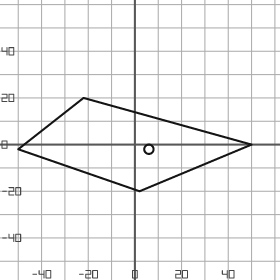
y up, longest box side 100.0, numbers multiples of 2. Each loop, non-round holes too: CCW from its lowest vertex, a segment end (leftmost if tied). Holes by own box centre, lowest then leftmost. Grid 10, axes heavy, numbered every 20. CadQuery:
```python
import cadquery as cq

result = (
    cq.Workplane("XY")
    .moveTo(2.0, -20.0)
    .lineTo(50.0, 0.0)
    .lineTo(-22.0, 20.0)
    .lineTo(-50.0, -2.0)
    .close()
    .moveTo(6.0, -2.0)
    .circle(2.0)
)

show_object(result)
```